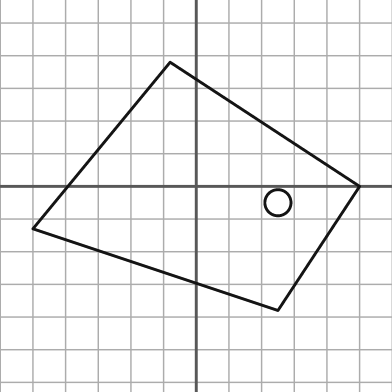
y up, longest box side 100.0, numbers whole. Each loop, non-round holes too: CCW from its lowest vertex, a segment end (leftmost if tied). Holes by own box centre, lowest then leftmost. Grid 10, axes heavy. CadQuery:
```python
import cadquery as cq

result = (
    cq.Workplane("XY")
    .moveTo(25.0, -38.0)
    .lineTo(50.0, 0.0)
    .lineTo(-8.0, 38.0)
    .lineTo(-50.0, -13.0)
    .close()
    .moveTo(25.0, -5.0)
    .circle(4.0)
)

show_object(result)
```